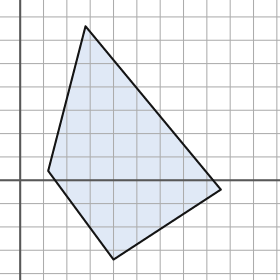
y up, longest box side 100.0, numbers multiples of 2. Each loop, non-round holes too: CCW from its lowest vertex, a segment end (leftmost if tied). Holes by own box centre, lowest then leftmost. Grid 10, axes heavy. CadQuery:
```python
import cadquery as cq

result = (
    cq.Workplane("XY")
    .moveTo(40.0, -34.0)
    .lineTo(86.0, -4.0)
    .lineTo(28.0, 66.0)
    .lineTo(12.0, 4.0)
    .close()
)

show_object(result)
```